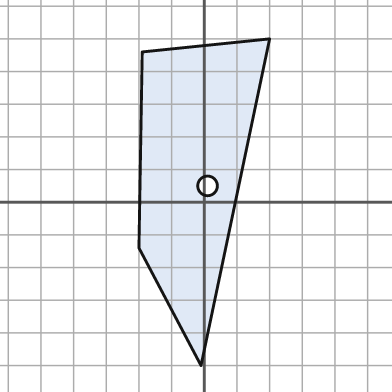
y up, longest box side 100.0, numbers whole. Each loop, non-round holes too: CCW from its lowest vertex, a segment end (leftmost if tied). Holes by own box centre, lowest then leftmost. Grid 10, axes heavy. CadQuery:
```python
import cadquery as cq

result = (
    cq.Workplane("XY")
    .moveTo(-1.0, -50.0)
    .lineTo(20.0, 50.0)
    .lineTo(-19.0, 46.0)
    .lineTo(-20.0, -14.0)
    .close()
    .moveTo(1.0, 5.0)
    .circle(3.0)
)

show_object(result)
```